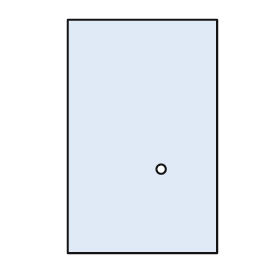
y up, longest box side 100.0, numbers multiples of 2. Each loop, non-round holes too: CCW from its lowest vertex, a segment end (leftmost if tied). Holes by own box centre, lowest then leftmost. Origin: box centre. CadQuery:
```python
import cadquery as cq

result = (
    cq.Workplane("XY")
    .moveTo(-32.0, -50.0)
    .lineTo(32.0, -50.0)
    .lineTo(32.0, 50.0)
    .lineTo(-32.0, 50.0)
    .close()
    .moveTo(8.0, -14.0)
    .circle(2.0)
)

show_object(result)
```